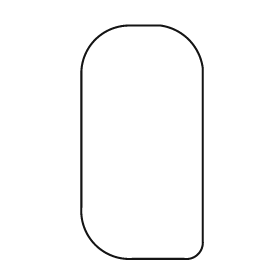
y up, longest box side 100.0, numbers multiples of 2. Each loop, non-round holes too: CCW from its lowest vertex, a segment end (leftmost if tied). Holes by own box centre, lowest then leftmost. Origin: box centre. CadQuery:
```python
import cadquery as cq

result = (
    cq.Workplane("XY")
    .moveTo(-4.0, -50.0)
    .lineTo(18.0, -50.0)
    .threePointArc((24.0, -48.0), (26.0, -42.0))
    .lineTo(26.0, 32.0)
    .threePointArc((20.0, 44.0), (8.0, 50.0))
    .lineTo(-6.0, 50.0)
    .threePointArc((-20.0, 44.0), (-26.0, 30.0))
    .lineTo(-26.0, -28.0)
    .threePointArc((-20.0, -44.0), (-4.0, -50.0))
    .close()
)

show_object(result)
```